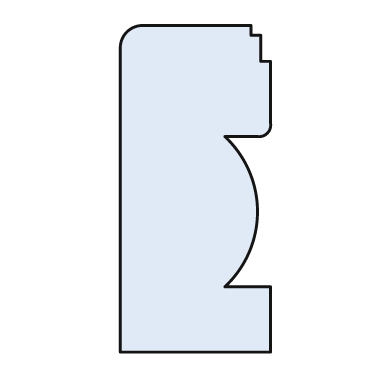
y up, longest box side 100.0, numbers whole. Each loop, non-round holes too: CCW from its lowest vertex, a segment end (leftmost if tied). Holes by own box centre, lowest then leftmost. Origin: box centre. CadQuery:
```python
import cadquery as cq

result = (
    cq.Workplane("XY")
    .moveTo(-23.0, -50.0)
    .lineTo(23.0, -50.0)
    .lineTo(23.0, -30.0)
    .lineTo(9.0, -30.0)
    .threePointArc((19.0, -7.0), (9.0, 16.0))
    .lineTo(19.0, 16.0)
    .threePointArc((22.0, 17.0), (23.0, 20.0))
    .lineTo(23.0, 39.0)
    .lineTo(20.0, 39.0)
    .lineTo(20.0, 47.0)
    .lineTo(17.0, 47.0)
    .lineTo(17.0, 50.0)
    .lineTo(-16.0, 50.0)
    .threePointArc((-21.0, 48.0), (-23.0, 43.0))
    .close()
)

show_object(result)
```